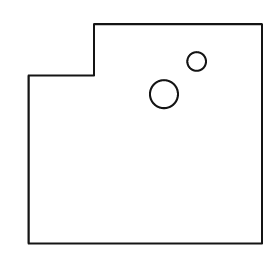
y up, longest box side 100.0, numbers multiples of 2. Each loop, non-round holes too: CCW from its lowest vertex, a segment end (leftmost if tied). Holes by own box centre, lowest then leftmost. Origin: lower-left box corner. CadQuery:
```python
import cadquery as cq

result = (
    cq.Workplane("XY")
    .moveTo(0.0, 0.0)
    .lineTo(100.0, 0.0)
    .lineTo(100.0, 94.0)
    .lineTo(28.0, 94.0)
    .lineTo(28.0, 72.0)
    .lineTo(0.0, 72.0)
    .close()
    .moveTo(58.0, 64.0)
    .circle(6.0)
    .moveTo(72.0, 78.0)
    .circle(4.0)
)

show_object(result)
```